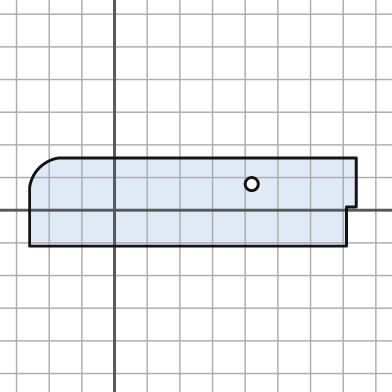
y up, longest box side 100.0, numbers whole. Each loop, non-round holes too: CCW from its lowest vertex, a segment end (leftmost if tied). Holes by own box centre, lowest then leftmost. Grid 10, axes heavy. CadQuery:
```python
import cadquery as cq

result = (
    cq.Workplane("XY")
    .moveTo(-26.0, -11.0)
    .lineTo(71.0, -11.0)
    .lineTo(71.0, 1.0)
    .lineTo(74.0, 1.0)
    .lineTo(74.0, 16.0)
    .lineTo(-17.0, 16.0)
    .threePointArc((-23.0, 13.0), (-26.0, 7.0))
    .close()
    .moveTo(42.0, 8.0)
    .circle(2.0)
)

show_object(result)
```